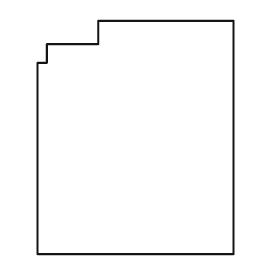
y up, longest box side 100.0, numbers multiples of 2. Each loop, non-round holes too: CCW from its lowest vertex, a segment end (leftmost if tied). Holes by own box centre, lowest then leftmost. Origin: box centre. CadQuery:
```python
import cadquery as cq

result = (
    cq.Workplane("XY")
    .moveTo(-42.0, -50.0)
    .lineTo(42.0, -50.0)
    .lineTo(42.0, 50.0)
    .lineTo(-16.0, 50.0)
    .lineTo(-16.0, 40.0)
    .lineTo(-38.0, 40.0)
    .lineTo(-38.0, 32.0)
    .lineTo(-42.0, 32.0)
    .close()
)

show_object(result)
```